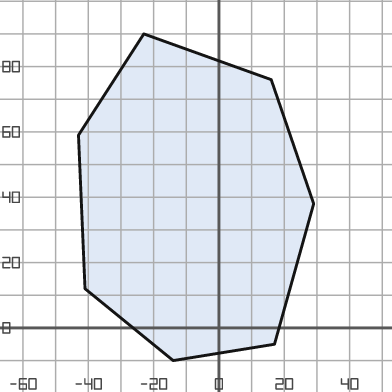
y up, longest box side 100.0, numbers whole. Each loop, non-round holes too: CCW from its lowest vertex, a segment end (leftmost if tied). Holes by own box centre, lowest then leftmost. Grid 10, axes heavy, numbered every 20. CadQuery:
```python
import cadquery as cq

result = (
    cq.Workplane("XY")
    .moveTo(-14.0, -10.0)
    .lineTo(17.0, -5.0)
    .lineTo(29.0, 38.0)
    .lineTo(16.0, 76.0)
    .lineTo(-23.0, 90.0)
    .lineTo(-43.0, 59.0)
    .lineTo(-41.0, 12.0)
    .close()
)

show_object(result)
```